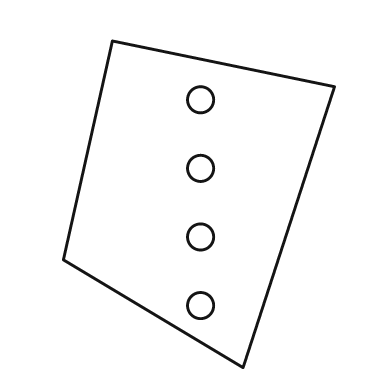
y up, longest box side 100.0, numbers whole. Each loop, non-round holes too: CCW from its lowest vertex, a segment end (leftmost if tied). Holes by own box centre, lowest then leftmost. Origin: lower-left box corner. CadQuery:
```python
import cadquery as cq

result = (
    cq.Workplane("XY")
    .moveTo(55.0, 0.0)
    .lineTo(83.0, 86.0)
    .lineTo(15.0, 100.0)
    .lineTo(0.0, 33.0)
    .close()
    .moveTo(42.0, 19.0)
    .circle(4.0)
    .moveTo(42.0, 40.0)
    .circle(4.0)
    .moveTo(42.0, 61.0)
    .circle(4.0)
    .moveTo(42.0, 82.0)
    .circle(4.0)
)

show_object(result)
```